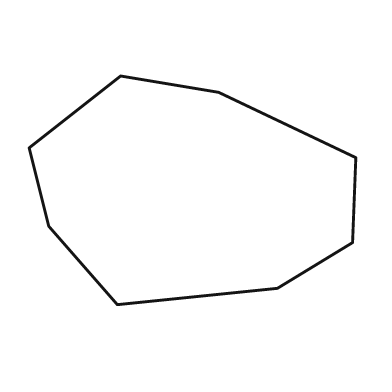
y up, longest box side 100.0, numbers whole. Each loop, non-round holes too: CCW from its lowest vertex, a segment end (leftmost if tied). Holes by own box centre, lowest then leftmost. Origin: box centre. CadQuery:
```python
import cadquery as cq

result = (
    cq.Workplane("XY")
    .moveTo(-23.0, -35.0)
    .lineTo(26.0, -30.0)
    .lineTo(49.0, -16.0)
    .lineTo(50.0, 10.0)
    .lineTo(8.0, 30.0)
    .lineTo(-22.0, 35.0)
    .lineTo(-50.0, 13.0)
    .lineTo(-44.0, -11.0)
    .close()
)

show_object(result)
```